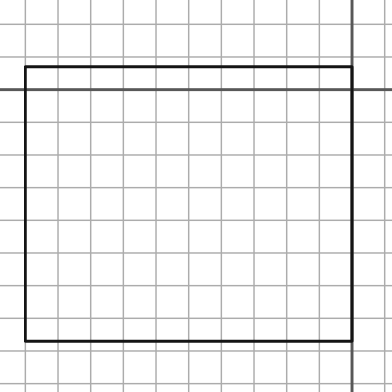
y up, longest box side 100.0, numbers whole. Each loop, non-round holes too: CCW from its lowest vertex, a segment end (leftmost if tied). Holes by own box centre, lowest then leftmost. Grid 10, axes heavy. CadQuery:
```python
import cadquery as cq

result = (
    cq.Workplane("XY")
    .moveTo(-100.0, -77.0)
    .lineTo(0.0, -77.0)
    .lineTo(0.0, 7.0)
    .lineTo(-100.0, 7.0)
    .close()
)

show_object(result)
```